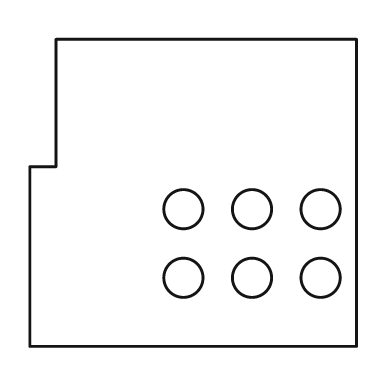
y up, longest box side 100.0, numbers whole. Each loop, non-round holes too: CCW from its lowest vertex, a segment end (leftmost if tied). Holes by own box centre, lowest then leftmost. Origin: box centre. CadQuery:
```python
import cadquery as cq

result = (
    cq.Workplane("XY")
    .moveTo(-50.0, -47.0)
    .lineTo(50.0, -47.0)
    .lineTo(50.0, 47.0)
    .lineTo(-42.0, 47.0)
    .lineTo(-42.0, 8.0)
    .lineTo(-50.0, 8.0)
    .close()
    .moveTo(-3.0, -26.0)
    .circle(6.0)
    .moveTo(18.0, -26.0)
    .circle(6.0)
    .moveTo(39.0, -26.0)
    .circle(6.0)
    .moveTo(-3.0, -5.0)
    .circle(6.0)
    .moveTo(18.0, -5.0)
    .circle(6.0)
    .moveTo(39.0, -5.0)
    .circle(6.0)
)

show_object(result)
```